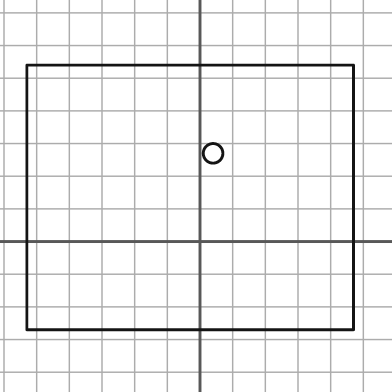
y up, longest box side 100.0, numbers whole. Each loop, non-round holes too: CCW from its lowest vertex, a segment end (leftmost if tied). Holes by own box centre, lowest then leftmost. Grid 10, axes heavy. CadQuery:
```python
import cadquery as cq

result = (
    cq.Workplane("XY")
    .moveTo(-53.0, -27.0)
    .lineTo(47.0, -27.0)
    .lineTo(47.0, 54.0)
    .lineTo(-53.0, 54.0)
    .close()
    .moveTo(4.0, 27.0)
    .circle(3.0)
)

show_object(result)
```